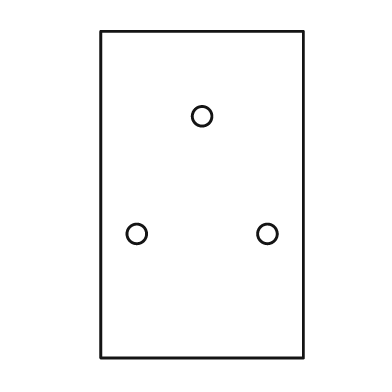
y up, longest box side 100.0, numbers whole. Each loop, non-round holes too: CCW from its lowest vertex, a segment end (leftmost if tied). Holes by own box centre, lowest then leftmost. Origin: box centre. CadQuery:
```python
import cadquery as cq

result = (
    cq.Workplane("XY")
    .moveTo(-31.0, -50.0)
    .lineTo(31.0, -50.0)
    .lineTo(31.0, 50.0)
    .lineTo(-31.0, 50.0)
    .close()
    .moveTo(-20.0, -12.0)
    .circle(3.0)
    .moveTo(20.0, -12.0)
    .circle(3.0)
    .moveTo(0.0, 24.0)
    .circle(3.0)
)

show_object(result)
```